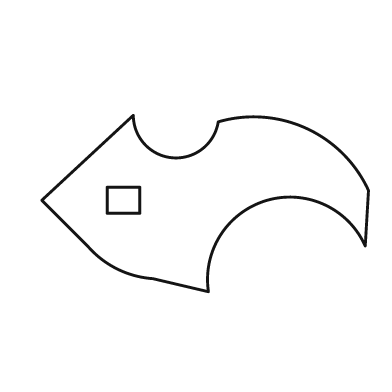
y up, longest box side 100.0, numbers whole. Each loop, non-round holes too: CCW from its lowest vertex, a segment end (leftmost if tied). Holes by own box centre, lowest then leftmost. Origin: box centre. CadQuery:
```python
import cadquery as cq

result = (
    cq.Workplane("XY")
    .moveTo(1.0, -27.0)
    .threePointArc((19.0, 1.0), (49.0, -13.0))
    .lineTo(50.0, 4.0)
    .threePointArc((31.0, 23.0), (4.0, 25.0))
    .threePointArc((-10.0, 14.0), (-22.0, 27.0))
    .lineTo(-50.0, 1.0)
    .lineTo(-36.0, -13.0)
    .threePointArc((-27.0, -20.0), (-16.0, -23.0))
    .close()
    .moveTo(-30.0, -3.0)
    .lineTo(-20.0, -3.0)
    .lineTo(-20.0, 5.0)
    .lineTo(-30.0, 5.0)
    .close()
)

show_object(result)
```